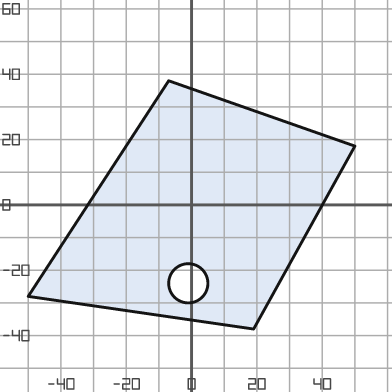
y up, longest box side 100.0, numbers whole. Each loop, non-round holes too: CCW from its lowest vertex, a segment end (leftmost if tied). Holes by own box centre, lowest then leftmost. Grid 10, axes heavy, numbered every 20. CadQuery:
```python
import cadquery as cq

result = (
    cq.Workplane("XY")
    .moveTo(19.0, -38.0)
    .lineTo(50.0, 18.0)
    .lineTo(-7.0, 38.0)
    .lineTo(-50.0, -28.0)
    .close()
    .moveTo(-1.0, -24.0)
    .circle(6.0)
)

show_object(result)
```